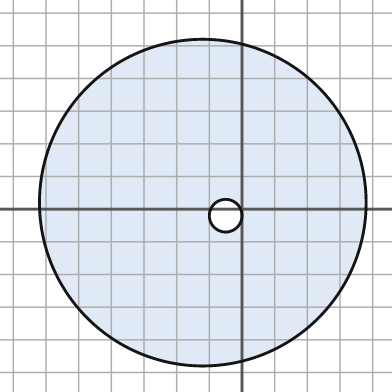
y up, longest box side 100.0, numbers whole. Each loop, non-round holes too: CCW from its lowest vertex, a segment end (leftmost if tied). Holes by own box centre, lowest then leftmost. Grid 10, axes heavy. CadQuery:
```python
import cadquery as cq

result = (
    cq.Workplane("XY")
    .moveTo(-12.0, 2.0)
    .circle(50.0)
    .moveTo(-5.0, -2.0)
    .circle(5.0)
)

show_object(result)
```